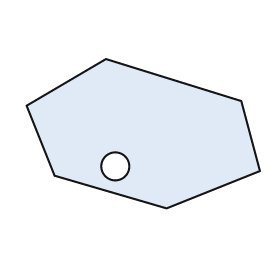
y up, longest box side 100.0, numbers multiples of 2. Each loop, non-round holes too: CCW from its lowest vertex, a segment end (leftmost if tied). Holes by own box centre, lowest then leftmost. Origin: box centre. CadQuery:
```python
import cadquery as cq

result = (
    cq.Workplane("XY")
    .moveTo(10.0, -32.0)
    .lineTo(50.0, -16.0)
    .lineTo(42.0, 14.0)
    .lineTo(-16.0, 32.0)
    .lineTo(-50.0, 12.0)
    .lineTo(-38.0, -18.0)
    .close()
    .moveTo(-12.0, -14.0)
    .circle(6.0)
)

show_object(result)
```